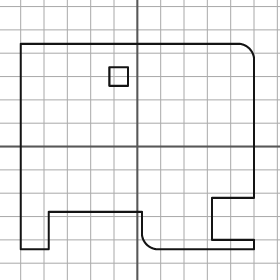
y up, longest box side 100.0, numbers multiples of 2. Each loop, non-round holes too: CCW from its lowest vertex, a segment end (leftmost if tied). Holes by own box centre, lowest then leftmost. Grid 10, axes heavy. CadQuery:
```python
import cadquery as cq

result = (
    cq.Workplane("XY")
    .moveTo(-50.0, -44.0)
    .lineTo(-38.0, -44.0)
    .lineTo(-38.0, -28.0)
    .lineTo(2.0, -28.0)
    .lineTo(2.0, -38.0)
    .threePointArc((4.0, -42.0), (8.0, -44.0))
    .lineTo(50.0, -44.0)
    .lineTo(50.0, -40.0)
    .lineTo(32.0, -40.0)
    .lineTo(32.0, -22.0)
    .lineTo(50.0, -22.0)
    .lineTo(50.0, 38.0)
    .threePointArc((48.0, 42.0), (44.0, 44.0))
    .lineTo(-50.0, 44.0)
    .close()
    .moveTo(-12.0, 26.0)
    .lineTo(-4.0, 26.0)
    .lineTo(-4.0, 34.0)
    .lineTo(-12.0, 34.0)
    .close()
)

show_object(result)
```